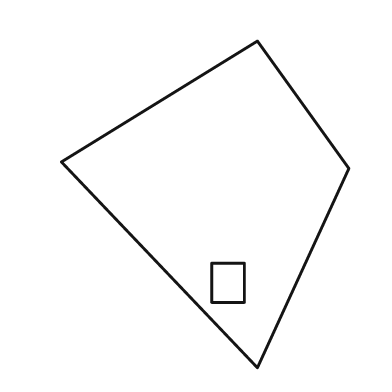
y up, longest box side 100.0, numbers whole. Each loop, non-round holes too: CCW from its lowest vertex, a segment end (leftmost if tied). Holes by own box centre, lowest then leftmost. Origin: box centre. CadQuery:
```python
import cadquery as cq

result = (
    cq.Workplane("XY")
    .moveTo(16.0, -50.0)
    .lineTo(44.0, 11.0)
    .lineTo(16.0, 50.0)
    .lineTo(-44.0, 13.0)
    .close()
    .moveTo(2.0, -30.0)
    .lineTo(12.0, -30.0)
    .lineTo(12.0, -18.0)
    .lineTo(2.0, -18.0)
    .close()
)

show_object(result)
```